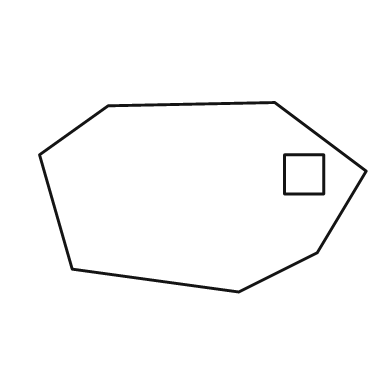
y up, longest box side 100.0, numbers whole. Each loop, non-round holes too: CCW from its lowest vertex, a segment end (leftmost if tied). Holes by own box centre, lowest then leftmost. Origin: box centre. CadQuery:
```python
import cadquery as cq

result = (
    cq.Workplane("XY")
    .moveTo(11.0, -29.0)
    .lineTo(35.0, -17.0)
    .lineTo(50.0, 8.0)
    .lineTo(22.0, 29.0)
    .lineTo(-29.0, 28.0)
    .lineTo(-50.0, 13.0)
    .lineTo(-40.0, -22.0)
    .close()
    .moveTo(25.0, 1.0)
    .lineTo(37.0, 1.0)
    .lineTo(37.0, 13.0)
    .lineTo(25.0, 13.0)
    .close()
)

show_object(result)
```